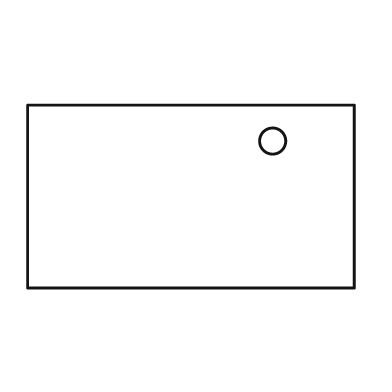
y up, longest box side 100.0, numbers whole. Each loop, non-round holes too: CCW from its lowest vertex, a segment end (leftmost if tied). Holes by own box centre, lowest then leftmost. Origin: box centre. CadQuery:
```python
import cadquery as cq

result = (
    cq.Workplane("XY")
    .moveTo(-50.0, -28.0)
    .lineTo(50.0, -28.0)
    .lineTo(50.0, 28.0)
    .lineTo(-50.0, 28.0)
    .close()
    .moveTo(25.0, 17.0)
    .circle(4.0)
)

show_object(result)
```